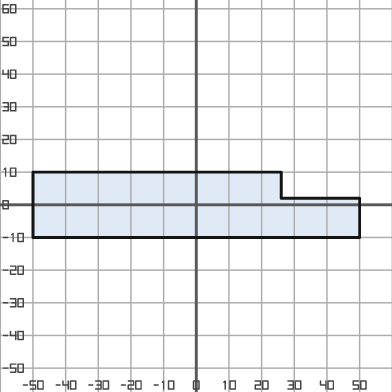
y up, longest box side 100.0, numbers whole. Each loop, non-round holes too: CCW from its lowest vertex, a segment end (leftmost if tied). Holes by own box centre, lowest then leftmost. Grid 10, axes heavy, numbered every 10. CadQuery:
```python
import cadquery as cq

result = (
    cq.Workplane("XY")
    .moveTo(-50.0, -10.0)
    .lineTo(50.0, -10.0)
    .lineTo(50.0, 2.0)
    .lineTo(26.0, 2.0)
    .lineTo(26.0, 10.0)
    .lineTo(-50.0, 10.0)
    .close()
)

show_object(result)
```